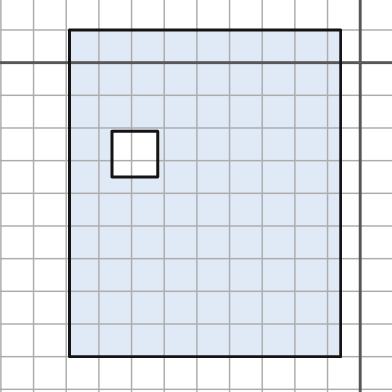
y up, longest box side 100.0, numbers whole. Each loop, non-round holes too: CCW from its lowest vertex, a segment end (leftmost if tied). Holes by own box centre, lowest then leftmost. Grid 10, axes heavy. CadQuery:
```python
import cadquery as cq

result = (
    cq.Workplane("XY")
    .moveTo(-89.0, -90.0)
    .lineTo(-6.0, -90.0)
    .lineTo(-6.0, 10.0)
    .lineTo(-89.0, 10.0)
    .close()
    .moveTo(-76.0, -35.0)
    .lineTo(-62.0, -35.0)
    .lineTo(-62.0, -21.0)
    .lineTo(-76.0, -21.0)
    .close()
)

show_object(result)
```